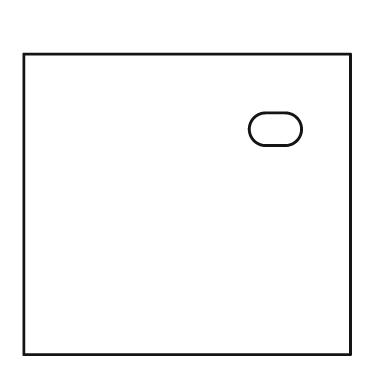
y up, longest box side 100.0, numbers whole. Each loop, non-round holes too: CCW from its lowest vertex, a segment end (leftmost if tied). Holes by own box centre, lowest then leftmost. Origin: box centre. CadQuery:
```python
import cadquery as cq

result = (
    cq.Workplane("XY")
    .moveTo(-50.0, -46.0)
    .lineTo(50.0, -46.0)
    .lineTo(50.0, 46.0)
    .lineTo(-50.0, 46.0)
    .close()
    .moveTo(24.0, 18.0)
    .lineTo(30.0, 18.0)
    .threePointArc((35.0, 23.0), (30.0, 28.0))
    .lineTo(24.0, 28.0)
    .threePointArc((19.0, 23.0), (24.0, 18.0))
    .close()
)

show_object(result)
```